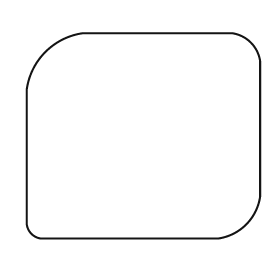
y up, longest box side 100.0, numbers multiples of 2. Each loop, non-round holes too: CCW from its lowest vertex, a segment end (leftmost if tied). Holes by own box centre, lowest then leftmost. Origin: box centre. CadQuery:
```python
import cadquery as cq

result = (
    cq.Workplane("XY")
    .moveTo(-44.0, -44.0)
    .lineTo(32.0, -44.0)
    .threePointArc((44.0, -38.0), (50.0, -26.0))
    .lineTo(50.0, 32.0)
    .threePointArc((46.0, 40.0), (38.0, 44.0))
    .lineTo(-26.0, 44.0)
    .threePointArc((-42.0, 36.0), (-50.0, 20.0))
    .lineTo(-50.0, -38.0)
    .threePointArc((-48.0, -42.0), (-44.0, -44.0))
    .close()
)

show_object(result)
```